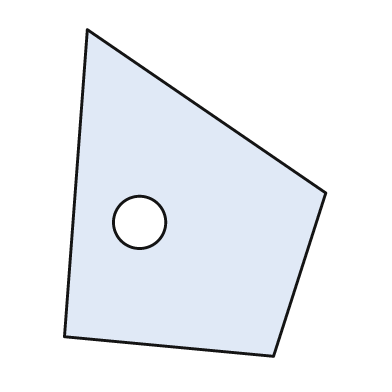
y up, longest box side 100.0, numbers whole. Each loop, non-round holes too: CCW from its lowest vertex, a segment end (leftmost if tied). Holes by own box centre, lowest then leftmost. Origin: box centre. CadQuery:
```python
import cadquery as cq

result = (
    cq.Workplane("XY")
    .moveTo(24.0, -50.0)
    .lineTo(40.0, 0.0)
    .lineTo(-33.0, 50.0)
    .lineTo(-40.0, -44.0)
    .close()
    .moveTo(-17.0, -9.0)
    .circle(8.0)
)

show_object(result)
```